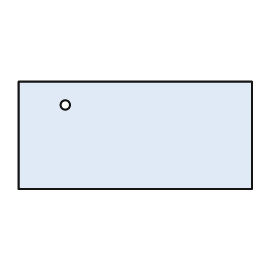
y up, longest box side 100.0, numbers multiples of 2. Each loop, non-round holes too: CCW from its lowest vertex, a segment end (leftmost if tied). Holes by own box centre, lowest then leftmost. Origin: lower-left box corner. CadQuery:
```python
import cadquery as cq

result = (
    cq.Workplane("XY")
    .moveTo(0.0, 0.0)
    .lineTo(100.0, 0.0)
    .lineTo(100.0, 46.0)
    .lineTo(0.0, 46.0)
    .close()
    .moveTo(20.0, 36.0)
    .circle(2.0)
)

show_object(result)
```